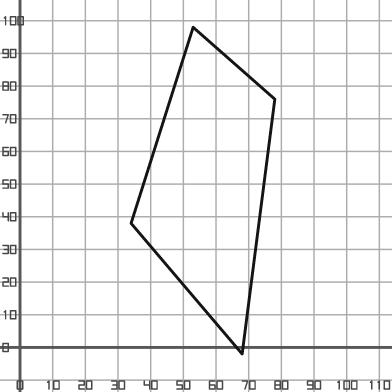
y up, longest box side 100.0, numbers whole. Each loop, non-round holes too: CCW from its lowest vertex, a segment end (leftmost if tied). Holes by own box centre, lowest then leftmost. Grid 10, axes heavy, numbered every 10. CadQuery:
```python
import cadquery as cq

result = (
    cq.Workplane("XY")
    .moveTo(68.0, -2.0)
    .lineTo(78.0, 76.0)
    .lineTo(53.0, 98.0)
    .lineTo(34.0, 38.0)
    .close()
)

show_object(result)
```